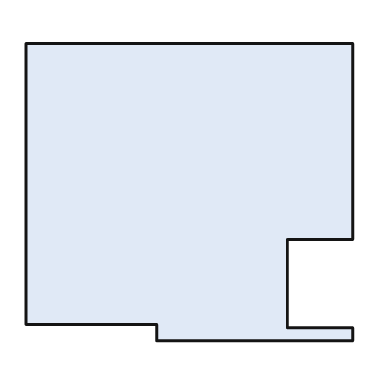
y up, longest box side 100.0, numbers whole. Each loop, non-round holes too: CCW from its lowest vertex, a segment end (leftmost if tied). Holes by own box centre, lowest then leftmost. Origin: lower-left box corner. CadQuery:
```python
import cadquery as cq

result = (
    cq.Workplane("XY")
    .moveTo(40.0, 0.0)
    .lineTo(100.0, 0.0)
    .lineTo(100.0, 4.0)
    .lineTo(80.0, 4.0)
    .lineTo(80.0, 31.0)
    .lineTo(100.0, 31.0)
    .lineTo(100.0, 91.0)
    .lineTo(0.0, 91.0)
    .lineTo(0.0, 5.0)
    .lineTo(40.0, 5.0)
    .close()
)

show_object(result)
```